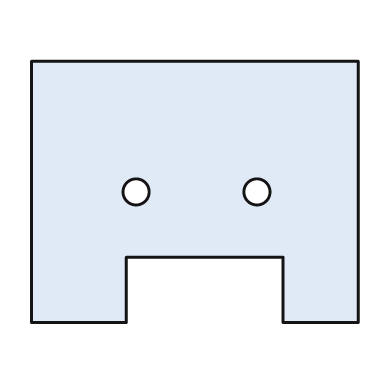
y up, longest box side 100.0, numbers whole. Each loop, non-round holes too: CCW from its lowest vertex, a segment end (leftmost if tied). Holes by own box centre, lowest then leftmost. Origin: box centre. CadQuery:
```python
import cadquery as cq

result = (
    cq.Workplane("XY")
    .moveTo(-50.0, -40.0)
    .lineTo(-21.0, -40.0)
    .lineTo(-21.0, -20.0)
    .lineTo(27.0, -20.0)
    .lineTo(27.0, -40.0)
    .lineTo(50.0, -40.0)
    .lineTo(50.0, 40.0)
    .lineTo(-50.0, 40.0)
    .close()
    .moveTo(-18.0, 0.0)
    .circle(4.0)
    .moveTo(19.0, 0.0)
    .circle(4.0)
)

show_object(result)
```